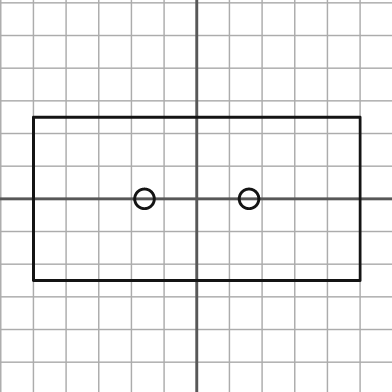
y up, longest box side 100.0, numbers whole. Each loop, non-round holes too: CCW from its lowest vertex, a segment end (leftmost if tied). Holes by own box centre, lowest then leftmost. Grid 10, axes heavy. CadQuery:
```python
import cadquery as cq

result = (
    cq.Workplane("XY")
    .moveTo(-50.0, -25.0)
    .lineTo(50.0, -25.0)
    .lineTo(50.0, 25.0)
    .lineTo(-50.0, 25.0)
    .close()
    .moveTo(-16.0, 0.0)
    .circle(3.0)
    .moveTo(16.0, 0.0)
    .circle(3.0)
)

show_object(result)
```